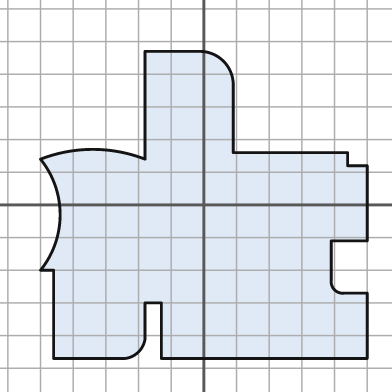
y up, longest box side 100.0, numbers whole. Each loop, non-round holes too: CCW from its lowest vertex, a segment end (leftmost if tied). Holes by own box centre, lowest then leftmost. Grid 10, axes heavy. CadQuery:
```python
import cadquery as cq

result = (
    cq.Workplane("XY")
    .moveTo(-46.0, -47.0)
    .lineTo(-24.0, -47.0)
    .threePointArc((-20.0, -45.0), (-18.0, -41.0))
    .lineTo(-18.0, -30.0)
    .lineTo(-13.0, -30.0)
    .lineTo(-13.0, -47.0)
    .lineTo(50.0, -47.0)
    .lineTo(50.0, -27.0)
    .lineTo(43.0, -27.0)
    .threePointArc((40.0, -26.0), (39.0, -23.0))
    .lineTo(39.0, -11.0)
    .lineTo(50.0, -11.0)
    .lineTo(50.0, 12.0)
    .lineTo(44.0, 12.0)
    .lineTo(44.0, 16.0)
    .lineTo(9.0, 16.0)
    .lineTo(9.0, 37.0)
    .threePointArc((6.0, 44.0), (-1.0, 47.0))
    .lineTo(-18.0, 47.0)
    .lineTo(-18.0, 14.0)
    .threePointArc((-34.0, 17.0), (-50.0, 14.0))
    .threePointArc((-44.0, -3.0), (-50.0, -20.0))
    .lineTo(-46.0, -20.0)
    .close()
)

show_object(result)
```